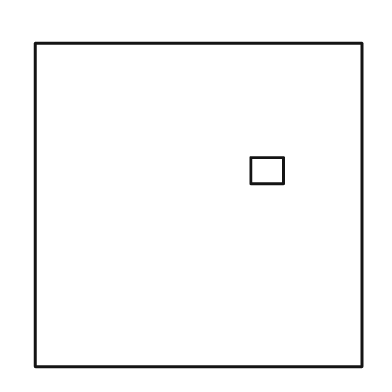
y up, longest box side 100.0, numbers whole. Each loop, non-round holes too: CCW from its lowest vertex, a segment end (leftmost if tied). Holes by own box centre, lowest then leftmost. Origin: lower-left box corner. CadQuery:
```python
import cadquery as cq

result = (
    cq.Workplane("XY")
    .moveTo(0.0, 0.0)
    .lineTo(100.0, 0.0)
    .lineTo(100.0, 99.0)
    .lineTo(0.0, 99.0)
    .close()
    .moveTo(66.0, 56.0)
    .lineTo(76.0, 56.0)
    .lineTo(76.0, 64.0)
    .lineTo(66.0, 64.0)
    .close()
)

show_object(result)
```